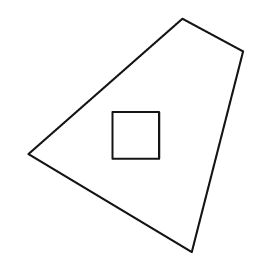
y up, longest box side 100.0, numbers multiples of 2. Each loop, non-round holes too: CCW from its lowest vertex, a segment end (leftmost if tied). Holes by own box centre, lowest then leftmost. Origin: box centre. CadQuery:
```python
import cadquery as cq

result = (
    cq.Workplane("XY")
    .moveTo(24.0, -50.0)
    .lineTo(46.0, 36.0)
    .lineTo(20.0, 50.0)
    .lineTo(-46.0, -8.0)
    .close()
    .moveTo(-10.0, -10.0)
    .lineTo(10.0, -10.0)
    .lineTo(10.0, 10.0)
    .lineTo(-10.0, 10.0)
    .close()
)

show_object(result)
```